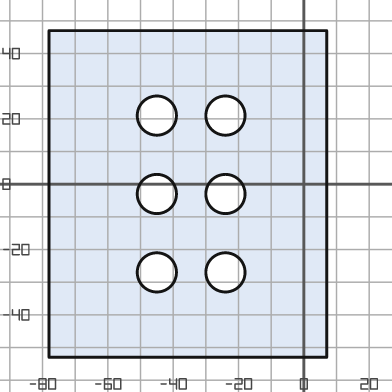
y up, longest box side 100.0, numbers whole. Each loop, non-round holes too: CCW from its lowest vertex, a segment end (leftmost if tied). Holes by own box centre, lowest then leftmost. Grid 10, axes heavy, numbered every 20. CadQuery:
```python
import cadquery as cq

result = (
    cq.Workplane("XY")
    .moveTo(-78.0, -53.0)
    .lineTo(7.0, -53.0)
    .lineTo(7.0, 47.0)
    .lineTo(-78.0, 47.0)
    .close()
    .moveTo(-45.0, -27.0)
    .circle(6.0)
    .moveTo(-24.0, -27.0)
    .circle(6.0)
    .moveTo(-45.0, -3.0)
    .circle(6.0)
    .moveTo(-24.0, -3.0)
    .circle(6.0)
    .moveTo(-45.0, 21.0)
    .circle(6.0)
    .moveTo(-24.0, 21.0)
    .circle(6.0)
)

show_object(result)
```